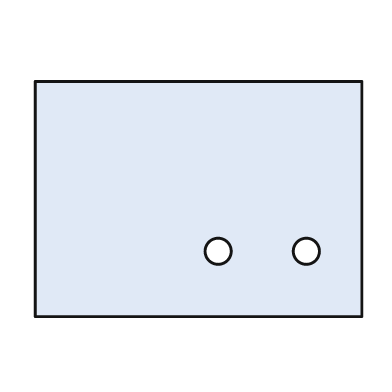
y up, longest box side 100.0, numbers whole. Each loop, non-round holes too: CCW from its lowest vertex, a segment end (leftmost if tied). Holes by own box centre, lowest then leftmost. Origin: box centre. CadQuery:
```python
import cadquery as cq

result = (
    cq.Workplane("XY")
    .moveTo(-50.0, -36.0)
    .lineTo(50.0, -36.0)
    .lineTo(50.0, 36.0)
    .lineTo(-50.0, 36.0)
    .close()
    .moveTo(6.0, -16.0)
    .circle(4.0)
    .moveTo(33.0, -16.0)
    .circle(4.0)
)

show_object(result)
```